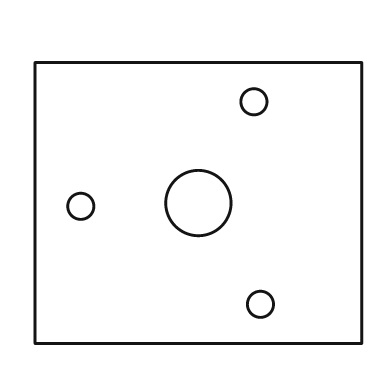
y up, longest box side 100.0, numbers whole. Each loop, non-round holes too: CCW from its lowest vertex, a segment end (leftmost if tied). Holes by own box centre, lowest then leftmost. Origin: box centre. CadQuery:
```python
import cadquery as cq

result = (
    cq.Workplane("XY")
    .moveTo(-50.0, -43.0)
    .lineTo(50.0, -43.0)
    .lineTo(50.0, 43.0)
    .lineTo(-50.0, 43.0)
    .close()
    .moveTo(19.0, -31.0)
    .circle(4.0)
    .moveTo(-36.0, -1.0)
    .circle(4.0)
    .moveTo(0.0, 0.0)
    .circle(10.0)
    .moveTo(17.0, 31.0)
    .circle(4.0)
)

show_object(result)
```